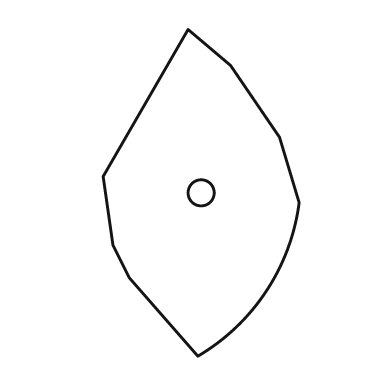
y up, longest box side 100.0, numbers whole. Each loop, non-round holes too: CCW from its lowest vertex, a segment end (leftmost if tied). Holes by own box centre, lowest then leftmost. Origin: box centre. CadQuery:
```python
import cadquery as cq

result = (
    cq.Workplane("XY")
    .moveTo(-1.0, -50.0)
    .threePointArc((20.0, -30.0), (30.0, -3.0))
    .lineTo(24.0, 17.0)
    .lineTo(9.0, 39.0)
    .lineTo(-4.0, 50.0)
    .lineTo(-30.0, 5.0)
    .lineTo(-27.0, -16.0)
    .lineTo(-22.0, -26.0)
    .close()
    .moveTo(0.0, 0.0)
    .circle(4.0)
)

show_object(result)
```